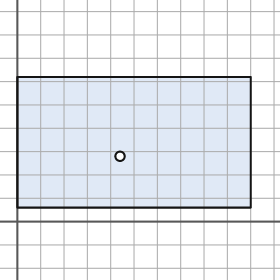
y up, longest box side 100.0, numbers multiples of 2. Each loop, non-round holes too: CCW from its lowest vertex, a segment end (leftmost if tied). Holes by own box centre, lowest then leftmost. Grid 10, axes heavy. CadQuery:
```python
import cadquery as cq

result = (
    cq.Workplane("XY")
    .moveTo(0.0, 6.0)
    .lineTo(100.0, 6.0)
    .lineTo(100.0, 62.0)
    .lineTo(0.0, 62.0)
    .close()
    .moveTo(44.0, 28.0)
    .circle(2.0)
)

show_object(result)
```